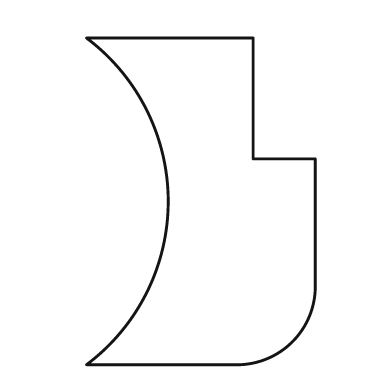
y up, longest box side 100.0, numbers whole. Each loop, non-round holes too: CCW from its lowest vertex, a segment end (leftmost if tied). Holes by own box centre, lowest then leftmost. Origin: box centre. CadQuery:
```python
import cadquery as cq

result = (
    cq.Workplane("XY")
    .moveTo(-35.0, -50.0)
    .lineTo(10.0, -50.0)
    .threePointArc((28.0, -43.0), (35.0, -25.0))
    .lineTo(35.0, 13.0)
    .lineTo(16.0, 13.0)
    .lineTo(16.0, 50.0)
    .lineTo(-35.0, 50.0)
    .threePointArc((-10.0, 0.0), (-35.0, -50.0))
    .close()
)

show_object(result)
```